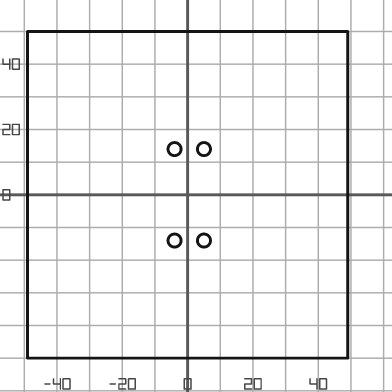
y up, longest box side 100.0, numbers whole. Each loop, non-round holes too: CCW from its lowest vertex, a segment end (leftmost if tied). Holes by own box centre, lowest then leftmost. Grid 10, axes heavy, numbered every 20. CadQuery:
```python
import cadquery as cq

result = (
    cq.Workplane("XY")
    .moveTo(-49.0, -50.0)
    .lineTo(49.0, -50.0)
    .lineTo(49.0, 50.0)
    .lineTo(-49.0, 50.0)
    .close()
    .moveTo(-4.0, -14.0)
    .circle(2.0)
    .moveTo(5.0, -14.0)
    .circle(2.0)
    .moveTo(-4.0, 14.0)
    .circle(2.0)
    .moveTo(5.0, 14.0)
    .circle(2.0)
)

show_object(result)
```